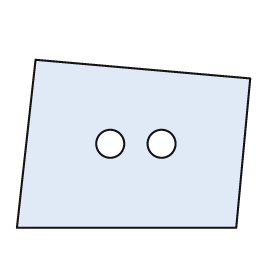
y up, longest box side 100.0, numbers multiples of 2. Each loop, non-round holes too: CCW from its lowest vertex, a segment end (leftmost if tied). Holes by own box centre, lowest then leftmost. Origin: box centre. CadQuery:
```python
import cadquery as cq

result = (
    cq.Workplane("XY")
    .moveTo(-50.0, -36.0)
    .lineTo(44.0, -36.0)
    .lineTo(50.0, 28.0)
    .lineTo(-42.0, 36.0)
    .close()
    .moveTo(-10.0, 0.0)
    .circle(6.0)
    .moveTo(12.0, 0.0)
    .circle(6.0)
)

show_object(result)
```